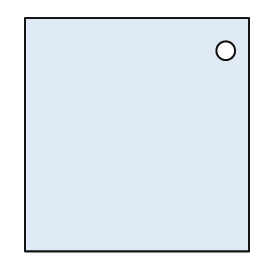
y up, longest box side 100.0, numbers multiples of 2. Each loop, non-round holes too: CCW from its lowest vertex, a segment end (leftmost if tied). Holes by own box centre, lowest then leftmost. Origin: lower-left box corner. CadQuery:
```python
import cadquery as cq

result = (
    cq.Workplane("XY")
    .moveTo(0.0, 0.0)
    .lineTo(96.0, 0.0)
    .lineTo(96.0, 100.0)
    .lineTo(0.0, 100.0)
    .close()
    .moveTo(86.0, 86.0)
    .circle(4.0)
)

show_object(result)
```